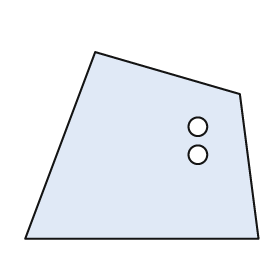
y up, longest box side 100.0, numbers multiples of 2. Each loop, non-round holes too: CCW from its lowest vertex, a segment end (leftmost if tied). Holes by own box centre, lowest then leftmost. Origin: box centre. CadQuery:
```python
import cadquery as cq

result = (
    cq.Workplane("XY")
    .moveTo(-50.0, -40.0)
    .lineTo(50.0, -40.0)
    .lineTo(42.0, 22.0)
    .lineTo(-20.0, 40.0)
    .close()
    .moveTo(24.0, -4.0)
    .circle(4.0)
    .moveTo(24.0, 8.0)
    .circle(4.0)
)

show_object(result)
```